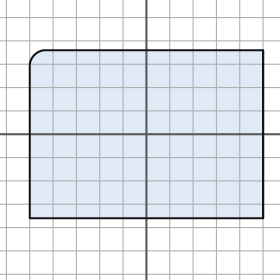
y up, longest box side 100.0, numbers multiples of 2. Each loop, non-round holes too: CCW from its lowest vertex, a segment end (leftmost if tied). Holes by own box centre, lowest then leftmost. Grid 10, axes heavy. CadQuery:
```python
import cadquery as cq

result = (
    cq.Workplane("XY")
    .moveTo(-50.0, -36.0)
    .lineTo(50.0, -36.0)
    .lineTo(50.0, 36.0)
    .lineTo(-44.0, 36.0)
    .threePointArc((-48.0, 34.0), (-50.0, 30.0))
    .close()
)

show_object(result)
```